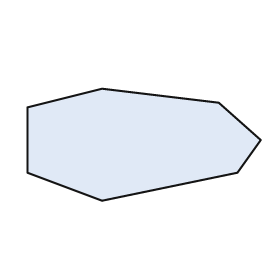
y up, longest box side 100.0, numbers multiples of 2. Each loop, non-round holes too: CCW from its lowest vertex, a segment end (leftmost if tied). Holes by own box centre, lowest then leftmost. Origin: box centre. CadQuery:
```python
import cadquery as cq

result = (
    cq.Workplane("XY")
    .moveTo(-18.0, -24.0)
    .lineTo(40.0, -12.0)
    .lineTo(50.0, 2.0)
    .lineTo(32.0, 18.0)
    .lineTo(-18.0, 24.0)
    .lineTo(-50.0, 16.0)
    .lineTo(-50.0, -12.0)
    .close()
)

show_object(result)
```